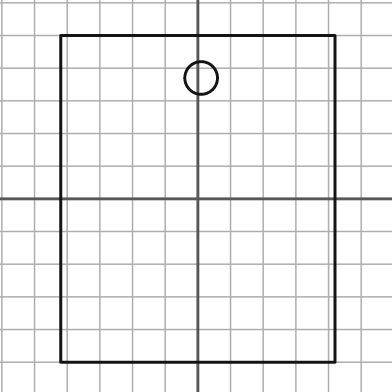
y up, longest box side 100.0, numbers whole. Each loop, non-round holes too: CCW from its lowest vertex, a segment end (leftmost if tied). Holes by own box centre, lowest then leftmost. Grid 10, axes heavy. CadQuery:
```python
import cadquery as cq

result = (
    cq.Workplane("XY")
    .moveTo(-42.0, -50.0)
    .lineTo(42.0, -50.0)
    .lineTo(42.0, 50.0)
    .lineTo(-42.0, 50.0)
    .close()
    .moveTo(1.0, 37.0)
    .circle(5.0)
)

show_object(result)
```